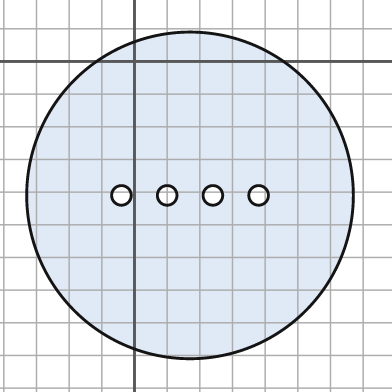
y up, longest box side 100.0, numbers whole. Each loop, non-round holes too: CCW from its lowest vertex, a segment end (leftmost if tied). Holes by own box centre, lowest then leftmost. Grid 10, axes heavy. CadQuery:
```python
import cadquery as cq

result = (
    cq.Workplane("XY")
    .moveTo(17.0, -41.0)
    .circle(50.0)
    .moveTo(-4.0, -41.0)
    .circle(3.0)
    .moveTo(10.0, -41.0)
    .circle(3.0)
    .moveTo(24.0, -41.0)
    .circle(3.0)
    .moveTo(38.0, -41.0)
    .circle(3.0)
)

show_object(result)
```